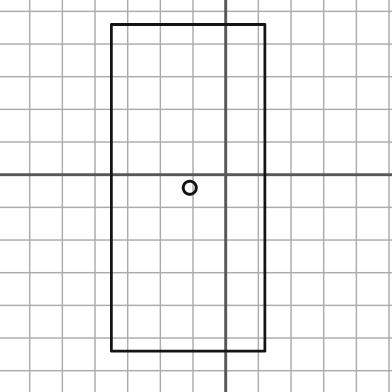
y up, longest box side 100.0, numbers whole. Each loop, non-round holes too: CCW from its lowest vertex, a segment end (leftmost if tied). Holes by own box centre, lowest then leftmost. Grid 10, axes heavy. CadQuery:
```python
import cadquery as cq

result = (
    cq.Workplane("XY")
    .moveTo(-35.0, -54.0)
    .lineTo(12.0, -54.0)
    .lineTo(12.0, 46.0)
    .lineTo(-35.0, 46.0)
    .close()
    .moveTo(-11.0, -4.0)
    .circle(2.0)
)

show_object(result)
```